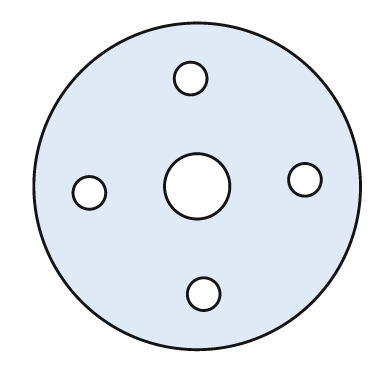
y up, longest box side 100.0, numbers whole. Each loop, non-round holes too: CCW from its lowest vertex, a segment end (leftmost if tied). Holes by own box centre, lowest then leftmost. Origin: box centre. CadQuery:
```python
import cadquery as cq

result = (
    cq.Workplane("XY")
    .moveTo(0.0, 0.0)
    .circle(50.0)
    .moveTo(2.0, -33.0)
    .circle(5.0)
    .moveTo(-33.0, -2.0)
    .circle(5.0)
    .moveTo(0.0, 0.0)
    .circle(10.0)
    .moveTo(33.0, 2.0)
    .circle(5.0)
    .moveTo(-2.0, 33.0)
    .circle(5.0)
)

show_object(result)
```